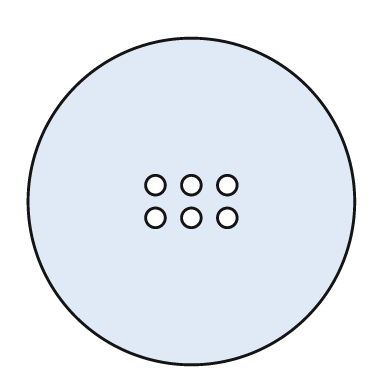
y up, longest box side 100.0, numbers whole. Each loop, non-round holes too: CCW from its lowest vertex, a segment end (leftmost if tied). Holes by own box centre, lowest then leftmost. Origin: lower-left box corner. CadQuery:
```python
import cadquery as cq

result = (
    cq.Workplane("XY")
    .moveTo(50.0, 50.0)
    .circle(50.0)
    .moveTo(39.0, 45.0)
    .circle(3.0)
    .moveTo(50.0, 45.0)
    .circle(3.0)
    .moveTo(61.0, 45.0)
    .circle(3.0)
    .moveTo(39.0, 55.0)
    .circle(3.0)
    .moveTo(50.0, 55.0)
    .circle(3.0)
    .moveTo(61.0, 55.0)
    .circle(3.0)
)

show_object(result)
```